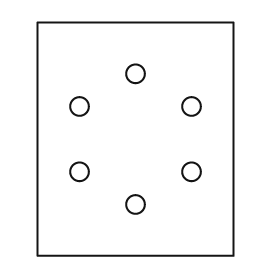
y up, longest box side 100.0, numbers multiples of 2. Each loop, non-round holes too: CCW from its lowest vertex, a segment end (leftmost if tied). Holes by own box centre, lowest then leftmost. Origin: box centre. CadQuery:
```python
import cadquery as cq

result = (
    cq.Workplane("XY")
    .moveTo(-42.0, -50.0)
    .lineTo(42.0, -50.0)
    .lineTo(42.0, 50.0)
    .lineTo(-42.0, 50.0)
    .close()
    .moveTo(0.0, -28.0)
    .circle(4.0)
    .moveTo(-24.0, -14.0)
    .circle(4.0)
    .moveTo(24.0, -14.0)
    .circle(4.0)
    .moveTo(-24.0, 14.0)
    .circle(4.0)
    .moveTo(24.0, 14.0)
    .circle(4.0)
    .moveTo(0.0, 28.0)
    .circle(4.0)
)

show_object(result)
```